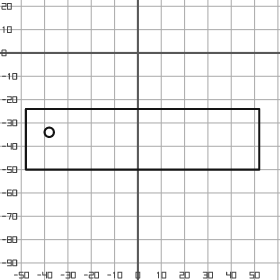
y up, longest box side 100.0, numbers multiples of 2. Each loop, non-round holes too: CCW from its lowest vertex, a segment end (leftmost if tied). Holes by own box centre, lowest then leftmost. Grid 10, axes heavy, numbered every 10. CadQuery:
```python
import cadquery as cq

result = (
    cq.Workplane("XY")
    .moveTo(-48.0, -50.0)
    .lineTo(52.0, -50.0)
    .lineTo(52.0, -24.0)
    .lineTo(-48.0, -24.0)
    .close()
    .moveTo(-38.0, -34.0)
    .circle(2.0)
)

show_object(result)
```